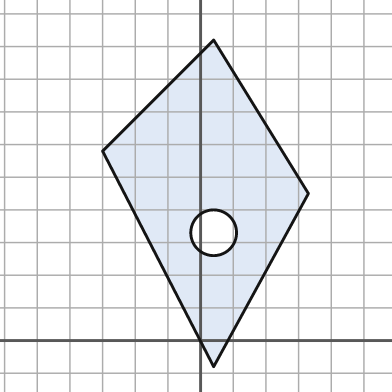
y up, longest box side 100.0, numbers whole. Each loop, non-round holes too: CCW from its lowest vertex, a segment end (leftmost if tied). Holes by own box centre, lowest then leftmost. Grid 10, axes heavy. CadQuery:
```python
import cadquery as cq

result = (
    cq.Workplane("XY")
    .moveTo(4.0, -8.0)
    .lineTo(33.0, 45.0)
    .lineTo(4.0, 92.0)
    .lineTo(-30.0, 58.0)
    .close()
    .moveTo(4.0, 33.0)
    .circle(7.0)
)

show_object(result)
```